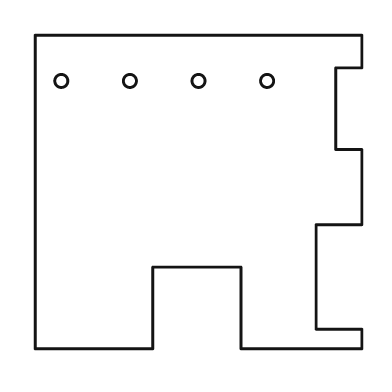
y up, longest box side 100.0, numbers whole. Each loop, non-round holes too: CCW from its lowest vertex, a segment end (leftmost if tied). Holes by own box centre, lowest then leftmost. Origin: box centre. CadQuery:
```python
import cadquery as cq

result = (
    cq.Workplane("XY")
    .moveTo(-50.0, -48.0)
    .lineTo(-14.0, -48.0)
    .lineTo(-14.0, -23.0)
    .lineTo(13.0, -23.0)
    .lineTo(13.0, -48.0)
    .lineTo(50.0, -48.0)
    .lineTo(50.0, -42.0)
    .lineTo(36.0, -42.0)
    .lineTo(36.0, -10.0)
    .lineTo(50.0, -10.0)
    .lineTo(50.0, 13.0)
    .lineTo(42.0, 13.0)
    .lineTo(42.0, 38.0)
    .lineTo(50.0, 38.0)
    .lineTo(50.0, 48.0)
    .lineTo(-50.0, 48.0)
    .close()
    .moveTo(-42.0, 34.0)
    .circle(2.0)
    .moveTo(-21.0, 34.0)
    .circle(2.0)
    .moveTo(0.0, 34.0)
    .circle(2.0)
    .moveTo(21.0, 34.0)
    .circle(2.0)
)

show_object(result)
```